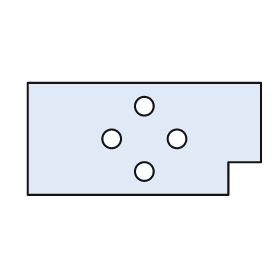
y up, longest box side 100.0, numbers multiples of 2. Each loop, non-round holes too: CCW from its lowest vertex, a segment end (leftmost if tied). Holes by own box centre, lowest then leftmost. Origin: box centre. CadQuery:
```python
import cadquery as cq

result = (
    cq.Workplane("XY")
    .moveTo(-50.0, -24.0)
    .lineTo(36.0, -24.0)
    .lineTo(36.0, -10.0)
    .lineTo(50.0, -10.0)
    .lineTo(50.0, 24.0)
    .lineTo(-50.0, 24.0)
    .close()
    .moveTo(0.0, -14.0)
    .circle(4.0)
    .moveTo(-14.0, 0.0)
    .circle(4.0)
    .moveTo(14.0, 0.0)
    .circle(4.0)
    .moveTo(0.0, 14.0)
    .circle(4.0)
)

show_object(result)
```